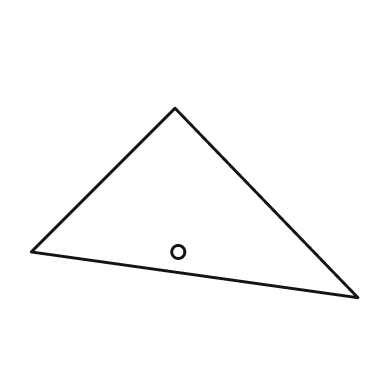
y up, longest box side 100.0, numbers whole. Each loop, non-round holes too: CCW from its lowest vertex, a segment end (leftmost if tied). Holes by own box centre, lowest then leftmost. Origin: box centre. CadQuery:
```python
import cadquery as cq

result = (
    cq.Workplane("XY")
    .moveTo(50.0, -29.0)
    .lineTo(-6.0, 29.0)
    .lineTo(-50.0, -15.0)
    .close()
    .moveTo(-5.0, -15.0)
    .circle(2.0)
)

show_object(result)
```